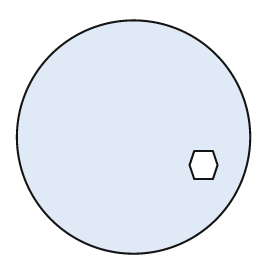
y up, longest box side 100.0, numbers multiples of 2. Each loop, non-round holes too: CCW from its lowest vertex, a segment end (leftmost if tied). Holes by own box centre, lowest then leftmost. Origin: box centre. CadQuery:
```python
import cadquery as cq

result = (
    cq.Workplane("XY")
    .moveTo(0.0, 0.0)
    .circle(50.0)
    .moveTo(26.0, -18.0)
    .lineTo(34.0, -18.0)
    .lineTo(36.0, -12.0)
    .lineTo(34.0, -6.0)
    .lineTo(26.0, -6.0)
    .lineTo(24.0, -12.0)
    .close()
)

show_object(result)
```